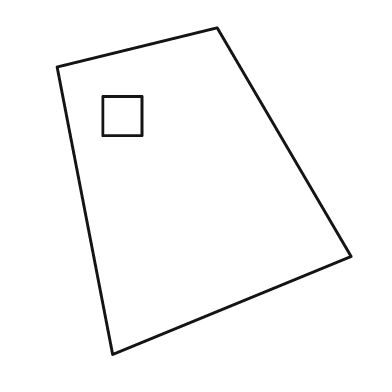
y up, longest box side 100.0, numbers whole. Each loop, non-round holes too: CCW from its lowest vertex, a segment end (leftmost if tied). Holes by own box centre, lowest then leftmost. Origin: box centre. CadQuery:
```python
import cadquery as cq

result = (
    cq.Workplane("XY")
    .moveTo(-28.0, -50.0)
    .lineTo(45.0, -20.0)
    .lineTo(4.0, 50.0)
    .lineTo(-45.0, 38.0)
    .close()
    .moveTo(-31.0, 17.0)
    .lineTo(-19.0, 17.0)
    .lineTo(-19.0, 29.0)
    .lineTo(-31.0, 29.0)
    .close()
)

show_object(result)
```